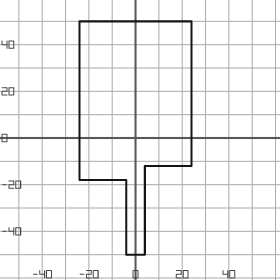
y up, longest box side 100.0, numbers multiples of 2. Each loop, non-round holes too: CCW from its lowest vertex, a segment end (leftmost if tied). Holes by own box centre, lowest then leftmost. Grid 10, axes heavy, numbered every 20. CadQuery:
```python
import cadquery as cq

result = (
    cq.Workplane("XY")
    .moveTo(-4.0, -50.0)
    .lineTo(4.0, -50.0)
    .lineTo(4.0, -12.0)
    .lineTo(24.0, -12.0)
    .lineTo(24.0, 50.0)
    .lineTo(-24.0, 50.0)
    .lineTo(-24.0, -18.0)
    .lineTo(-4.0, -18.0)
    .close()
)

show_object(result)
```